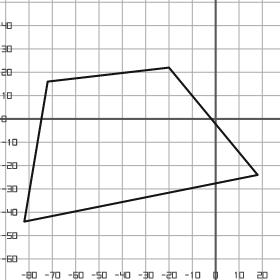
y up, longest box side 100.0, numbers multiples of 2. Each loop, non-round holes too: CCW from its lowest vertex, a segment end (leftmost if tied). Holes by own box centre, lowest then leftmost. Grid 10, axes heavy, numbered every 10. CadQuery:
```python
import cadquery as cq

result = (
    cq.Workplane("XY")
    .moveTo(-82.0, -44.0)
    .lineTo(18.0, -24.0)
    .lineTo(-20.0, 22.0)
    .lineTo(-72.0, 16.0)
    .close()
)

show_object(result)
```